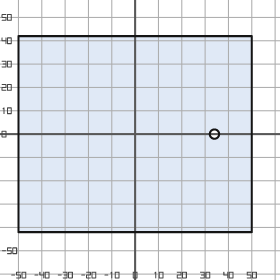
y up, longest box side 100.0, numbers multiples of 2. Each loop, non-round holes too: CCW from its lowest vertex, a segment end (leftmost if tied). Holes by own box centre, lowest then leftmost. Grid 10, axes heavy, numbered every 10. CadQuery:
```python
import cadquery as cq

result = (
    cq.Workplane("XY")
    .moveTo(-50.0, -42.0)
    .lineTo(50.0, -42.0)
    .lineTo(50.0, 42.0)
    .lineTo(-50.0, 42.0)
    .close()
    .moveTo(34.0, 0.0)
    .circle(2.0)
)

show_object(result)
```